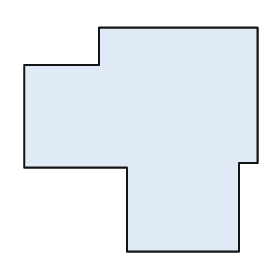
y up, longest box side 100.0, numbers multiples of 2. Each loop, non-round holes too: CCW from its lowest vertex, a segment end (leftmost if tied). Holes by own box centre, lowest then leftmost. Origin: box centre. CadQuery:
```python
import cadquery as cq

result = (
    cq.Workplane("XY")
    .moveTo(-6.0, -48.0)
    .lineTo(42.0, -48.0)
    .lineTo(42.0, -10.0)
    .lineTo(50.0, -10.0)
    .lineTo(50.0, 48.0)
    .lineTo(-18.0, 48.0)
    .lineTo(-18.0, 32.0)
    .lineTo(-50.0, 32.0)
    .lineTo(-50.0, -12.0)
    .lineTo(-6.0, -12.0)
    .close()
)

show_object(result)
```